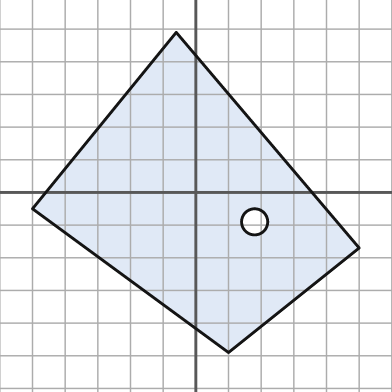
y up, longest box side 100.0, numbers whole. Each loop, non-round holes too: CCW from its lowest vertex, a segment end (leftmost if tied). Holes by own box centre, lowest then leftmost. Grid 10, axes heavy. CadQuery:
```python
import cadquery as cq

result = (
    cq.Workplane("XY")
    .moveTo(10.0, -49.0)
    .lineTo(50.0, -17.0)
    .lineTo(-6.0, 49.0)
    .lineTo(-50.0, -5.0)
    .close()
    .moveTo(18.0, -9.0)
    .circle(4.0)
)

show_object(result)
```